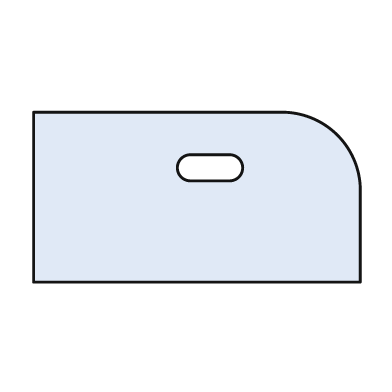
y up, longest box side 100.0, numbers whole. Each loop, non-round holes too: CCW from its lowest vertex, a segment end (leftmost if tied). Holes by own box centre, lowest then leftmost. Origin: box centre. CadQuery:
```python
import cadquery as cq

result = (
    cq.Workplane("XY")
    .moveTo(-50.0, -26.0)
    .lineTo(50.0, -26.0)
    .lineTo(50.0, 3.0)
    .threePointArc((43.0, 19.0), (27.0, 26.0))
    .lineTo(-50.0, 26.0)
    .close()
    .moveTo(-2.0, 5.0)
    .lineTo(10.0, 5.0)
    .threePointArc((14.0, 9.0), (10.0, 13.0))
    .lineTo(-2.0, 13.0)
    .threePointArc((-6.0, 9.0), (-2.0, 5.0))
    .close()
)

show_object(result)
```